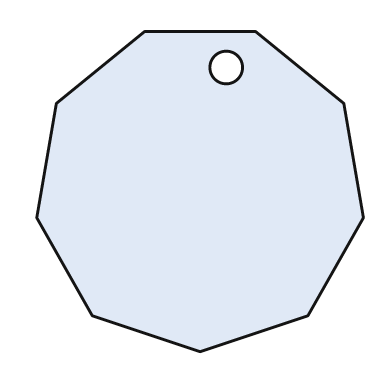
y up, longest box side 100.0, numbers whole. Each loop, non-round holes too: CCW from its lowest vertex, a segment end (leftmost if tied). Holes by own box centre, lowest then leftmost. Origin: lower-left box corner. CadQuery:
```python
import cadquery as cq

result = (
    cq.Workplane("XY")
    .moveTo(50.0, 0.0)
    .lineTo(83.0, 11.0)
    .lineTo(100.0, 41.0)
    .lineTo(94.0, 76.0)
    .lineTo(67.0, 98.0)
    .lineTo(33.0, 98.0)
    .lineTo(6.0, 76.0)
    .lineTo(0.0, 41.0)
    .lineTo(17.0, 11.0)
    .close()
    .moveTo(58.0, 87.0)
    .circle(5.0)
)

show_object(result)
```